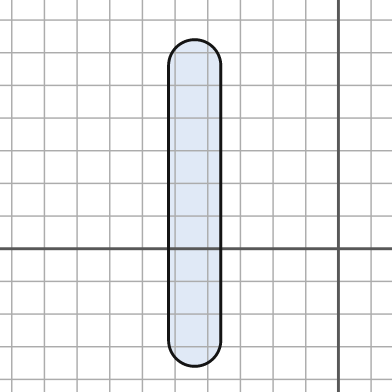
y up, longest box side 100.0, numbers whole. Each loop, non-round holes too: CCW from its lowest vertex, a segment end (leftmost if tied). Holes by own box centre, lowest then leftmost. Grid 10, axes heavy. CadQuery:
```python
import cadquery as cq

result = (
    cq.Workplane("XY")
    .moveTo(-52.0, -28.0)
    .threePointArc((-44.0, -36.0), (-36.0, -28.0))
    .lineTo(-36.0, 56.0)
    .threePointArc((-44.0, 64.0), (-52.0, 56.0))
    .close()
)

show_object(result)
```